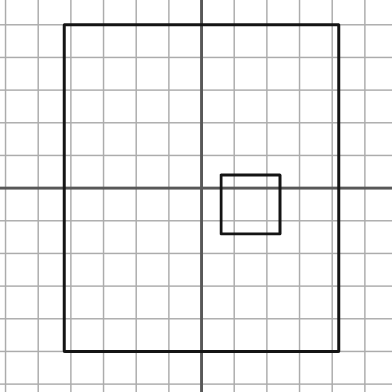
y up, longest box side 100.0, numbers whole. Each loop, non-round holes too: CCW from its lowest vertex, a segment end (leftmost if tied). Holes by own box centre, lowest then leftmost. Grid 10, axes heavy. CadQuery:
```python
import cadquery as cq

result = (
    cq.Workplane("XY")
    .moveTo(-42.0, -50.0)
    .lineTo(42.0, -50.0)
    .lineTo(42.0, 50.0)
    .lineTo(-42.0, 50.0)
    .close()
    .moveTo(6.0, -14.0)
    .lineTo(24.0, -14.0)
    .lineTo(24.0, 4.0)
    .lineTo(6.0, 4.0)
    .close()
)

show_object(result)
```